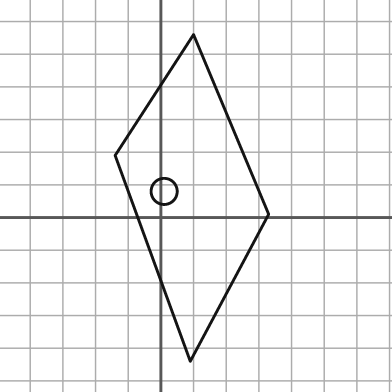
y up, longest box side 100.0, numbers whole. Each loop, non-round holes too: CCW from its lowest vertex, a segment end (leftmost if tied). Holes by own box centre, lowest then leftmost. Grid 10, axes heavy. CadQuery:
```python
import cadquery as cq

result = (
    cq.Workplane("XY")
    .moveTo(9.0, -44.0)
    .lineTo(33.0, 1.0)
    .lineTo(10.0, 56.0)
    .lineTo(-14.0, 19.0)
    .close()
    .moveTo(1.0, 8.0)
    .circle(4.0)
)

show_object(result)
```